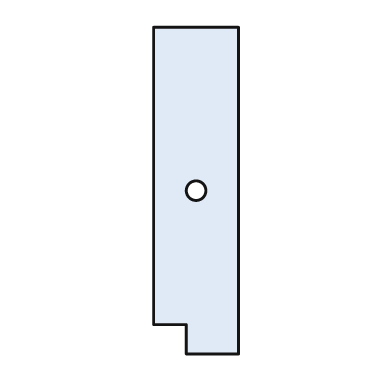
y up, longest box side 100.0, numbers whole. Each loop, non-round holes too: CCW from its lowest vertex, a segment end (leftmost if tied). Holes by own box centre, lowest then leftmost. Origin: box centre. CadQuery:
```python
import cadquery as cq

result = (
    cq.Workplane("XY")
    .moveTo(-3.0, -50.0)
    .lineTo(13.0, -50.0)
    .lineTo(13.0, 50.0)
    .lineTo(-13.0, 50.0)
    .lineTo(-13.0, -41.0)
    .lineTo(-3.0, -41.0)
    .close()
    .moveTo(0.0, 0.0)
    .circle(3.0)
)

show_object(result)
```